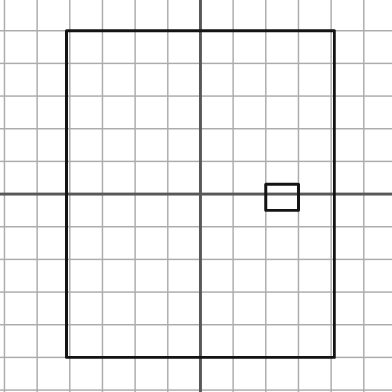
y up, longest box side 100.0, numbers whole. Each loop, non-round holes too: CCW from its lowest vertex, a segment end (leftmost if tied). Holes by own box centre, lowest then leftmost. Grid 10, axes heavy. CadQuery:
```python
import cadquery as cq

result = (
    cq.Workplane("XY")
    .moveTo(-41.0, -50.0)
    .lineTo(41.0, -50.0)
    .lineTo(41.0, 50.0)
    .lineTo(-41.0, 50.0)
    .close()
    .moveTo(20.0, -5.0)
    .lineTo(30.0, -5.0)
    .lineTo(30.0, 3.0)
    .lineTo(20.0, 3.0)
    .close()
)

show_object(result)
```